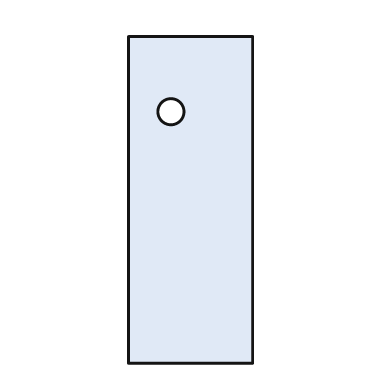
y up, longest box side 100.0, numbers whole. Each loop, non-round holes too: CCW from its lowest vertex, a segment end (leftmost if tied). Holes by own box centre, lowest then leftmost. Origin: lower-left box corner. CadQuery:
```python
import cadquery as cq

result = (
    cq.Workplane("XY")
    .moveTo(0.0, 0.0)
    .lineTo(38.0, 0.0)
    .lineTo(38.0, 100.0)
    .lineTo(0.0, 100.0)
    .close()
    .moveTo(13.0, 77.0)
    .circle(4.0)
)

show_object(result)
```